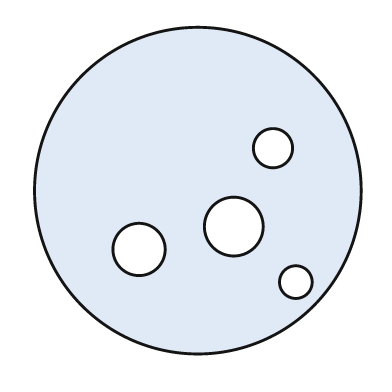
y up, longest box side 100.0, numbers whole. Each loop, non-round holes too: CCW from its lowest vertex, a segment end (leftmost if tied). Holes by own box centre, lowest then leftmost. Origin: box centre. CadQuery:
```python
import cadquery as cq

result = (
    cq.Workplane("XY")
    .moveTo(0.0, 0.0)
    .circle(50.0)
    .moveTo(30.0, -28.0)
    .circle(5.0)
    .moveTo(-18.0, -18.0)
    .circle(8.0)
    .moveTo(11.0, -11.0)
    .circle(9.0)
    .moveTo(23.0, 13.0)
    .circle(6.0)
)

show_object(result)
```